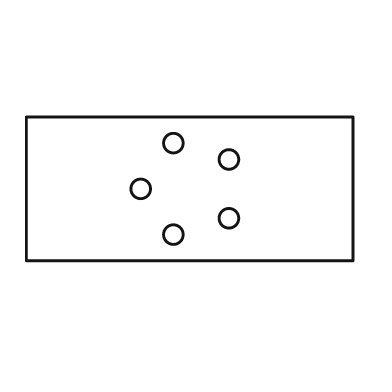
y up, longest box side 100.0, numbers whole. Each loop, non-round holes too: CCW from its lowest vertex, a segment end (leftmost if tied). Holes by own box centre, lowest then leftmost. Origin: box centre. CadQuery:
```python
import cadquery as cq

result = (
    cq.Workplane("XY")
    .moveTo(-50.0, -22.0)
    .lineTo(50.0, -22.0)
    .lineTo(50.0, 22.0)
    .lineTo(-50.0, 22.0)
    .close()
    .moveTo(-5.0, -14.0)
    .circle(3.0)
    .moveTo(12.0, -9.0)
    .circle(3.0)
    .moveTo(-15.0, 0.0)
    .circle(3.0)
    .moveTo(12.0, 9.0)
    .circle(3.0)
    .moveTo(-5.0, 14.0)
    .circle(3.0)
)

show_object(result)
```